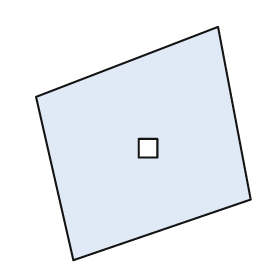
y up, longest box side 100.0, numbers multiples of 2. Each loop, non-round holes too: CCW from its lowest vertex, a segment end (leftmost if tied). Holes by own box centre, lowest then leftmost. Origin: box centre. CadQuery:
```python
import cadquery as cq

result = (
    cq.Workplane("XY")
    .moveTo(-30.0, -50.0)
    .lineTo(46.0, -24.0)
    .lineTo(32.0, 50.0)
    .lineTo(-46.0, 20.0)
    .close()
    .moveTo(-2.0, -6.0)
    .lineTo(6.0, -6.0)
    .lineTo(6.0, 2.0)
    .lineTo(-2.0, 2.0)
    .close()
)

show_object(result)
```